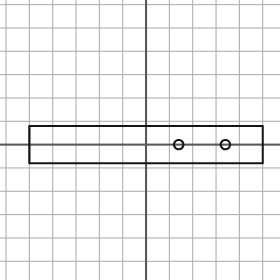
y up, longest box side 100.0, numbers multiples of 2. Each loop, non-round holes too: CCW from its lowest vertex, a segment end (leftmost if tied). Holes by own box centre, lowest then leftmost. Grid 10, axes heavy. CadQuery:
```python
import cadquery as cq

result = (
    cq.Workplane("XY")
    .moveTo(-50.0, -8.0)
    .lineTo(50.0, -8.0)
    .lineTo(50.0, 8.0)
    .lineTo(-50.0, 8.0)
    .close()
    .moveTo(14.0, 0.0)
    .circle(2.0)
    .moveTo(34.0, 0.0)
    .circle(2.0)
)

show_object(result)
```